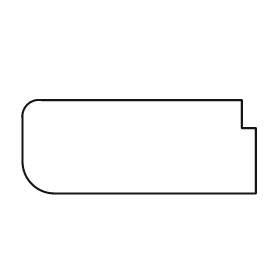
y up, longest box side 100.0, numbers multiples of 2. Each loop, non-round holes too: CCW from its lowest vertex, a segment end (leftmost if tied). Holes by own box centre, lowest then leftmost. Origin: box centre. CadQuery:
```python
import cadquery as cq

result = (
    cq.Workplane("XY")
    .moveTo(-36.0, -20.0)
    .lineTo(50.0, -20.0)
    .lineTo(50.0, 8.0)
    .lineTo(44.0, 8.0)
    .lineTo(44.0, 20.0)
    .lineTo(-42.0, 20.0)
    .threePointArc((-48.0, 18.0), (-50.0, 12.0))
    .lineTo(-50.0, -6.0)
    .threePointArc((-46.0, -16.0), (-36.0, -20.0))
    .close()
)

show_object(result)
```